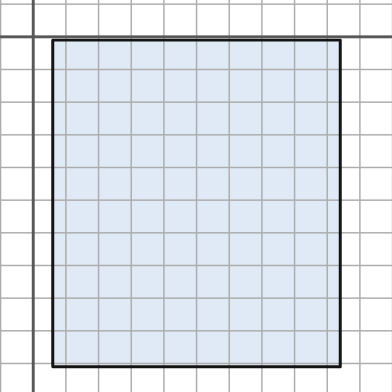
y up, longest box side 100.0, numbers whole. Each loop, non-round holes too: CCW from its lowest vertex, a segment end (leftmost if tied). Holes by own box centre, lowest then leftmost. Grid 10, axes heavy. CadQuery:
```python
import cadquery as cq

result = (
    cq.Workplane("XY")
    .moveTo(6.0, -101.0)
    .lineTo(94.0, -101.0)
    .lineTo(94.0, -1.0)
    .lineTo(6.0, -1.0)
    .close()
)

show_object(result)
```